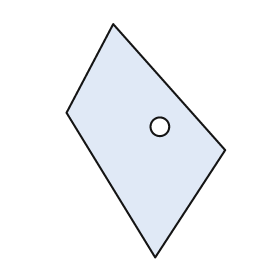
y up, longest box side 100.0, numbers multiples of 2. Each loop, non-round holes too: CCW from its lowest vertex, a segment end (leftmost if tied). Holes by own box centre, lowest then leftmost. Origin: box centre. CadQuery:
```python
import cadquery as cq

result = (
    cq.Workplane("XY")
    .moveTo(4.0, -50.0)
    .lineTo(34.0, -4.0)
    .lineTo(-14.0, 50.0)
    .lineTo(-34.0, 12.0)
    .close()
    .moveTo(6.0, 6.0)
    .circle(4.0)
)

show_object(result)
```